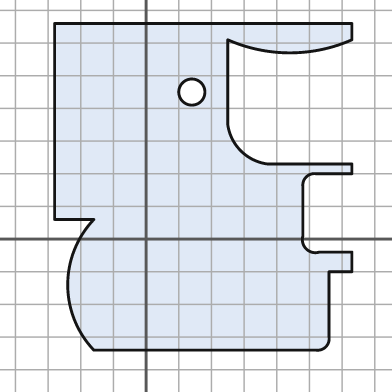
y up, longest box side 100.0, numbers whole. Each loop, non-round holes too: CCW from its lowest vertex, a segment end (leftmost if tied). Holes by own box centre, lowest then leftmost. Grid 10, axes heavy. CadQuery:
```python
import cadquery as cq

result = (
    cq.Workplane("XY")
    .moveTo(-16.0, -34.0)
    .lineTo(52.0, -34.0)
    .threePointArc((55.0, -33.0), (56.0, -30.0))
    .lineTo(56.0, -10.0)
    .lineTo(63.0, -10.0)
    .lineTo(63.0, -4.0)
    .lineTo(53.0, -4.0)
    .threePointArc((49.0, -3.0), (48.0, 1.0))
    .lineTo(48.0, 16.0)
    .threePointArc((49.0, 19.0), (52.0, 20.0))
    .lineTo(63.0, 20.0)
    .lineTo(63.0, 23.0)
    .lineTo(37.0, 23.0)
    .threePointArc((29.0, 27.0), (25.0, 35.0))
    .lineTo(25.0, 61.0)
    .threePointArc((44.0, 57.0), (63.0, 61.0))
    .lineTo(63.0, 66.0)
    .lineTo(-28.0, 66.0)
    .lineTo(-28.0, 6.0)
    .lineTo(-16.0, 6.0)
    .threePointArc((-24.0, -14.0), (-16.0, -34.0))
    .close()
    .moveTo(14.0, 45.0)
    .circle(4.0)
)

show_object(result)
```